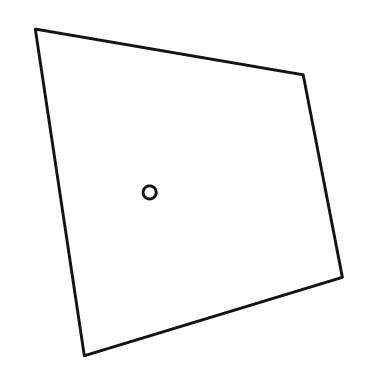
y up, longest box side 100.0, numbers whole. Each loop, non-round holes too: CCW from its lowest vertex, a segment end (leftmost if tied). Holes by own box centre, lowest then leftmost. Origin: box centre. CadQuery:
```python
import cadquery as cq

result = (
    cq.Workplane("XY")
    .moveTo(-32.0, -50.0)
    .lineTo(47.0, -26.0)
    .lineTo(35.0, 36.0)
    .lineTo(-47.0, 50.0)
    .close()
    .moveTo(-12.0, 0.0)
    .circle(2.0)
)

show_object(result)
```